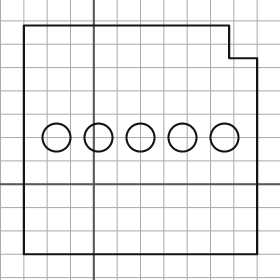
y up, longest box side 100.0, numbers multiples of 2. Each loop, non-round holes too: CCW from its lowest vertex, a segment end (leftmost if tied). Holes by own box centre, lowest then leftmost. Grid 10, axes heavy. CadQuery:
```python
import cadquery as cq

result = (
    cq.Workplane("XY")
    .moveTo(-30.0, -30.0)
    .lineTo(70.0, -30.0)
    .lineTo(70.0, 54.0)
    .lineTo(58.0, 54.0)
    .lineTo(58.0, 68.0)
    .lineTo(-30.0, 68.0)
    .close()
    .moveTo(-16.0, 20.0)
    .circle(6.0)
    .moveTo(2.0, 20.0)
    .circle(6.0)
    .moveTo(20.0, 20.0)
    .circle(6.0)
    .moveTo(38.0, 20.0)
    .circle(6.0)
    .moveTo(56.0, 20.0)
    .circle(6.0)
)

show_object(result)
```